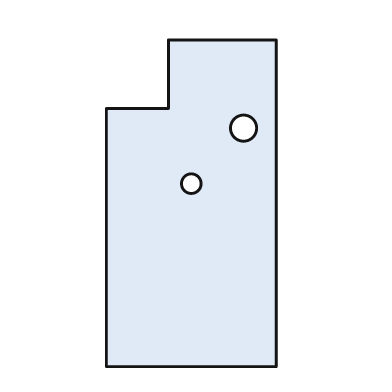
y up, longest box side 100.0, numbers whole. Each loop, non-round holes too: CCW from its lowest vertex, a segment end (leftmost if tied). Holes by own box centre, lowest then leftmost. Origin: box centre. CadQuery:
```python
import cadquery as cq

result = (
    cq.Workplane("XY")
    .moveTo(-26.0, -50.0)
    .lineTo(26.0, -50.0)
    .lineTo(26.0, 50.0)
    .lineTo(-7.0, 50.0)
    .lineTo(-7.0, 29.0)
    .lineTo(-26.0, 29.0)
    .close()
    .moveTo(0.0, 6.0)
    .circle(3.0)
    .moveTo(16.0, 23.0)
    .circle(4.0)
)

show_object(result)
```